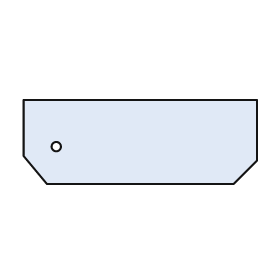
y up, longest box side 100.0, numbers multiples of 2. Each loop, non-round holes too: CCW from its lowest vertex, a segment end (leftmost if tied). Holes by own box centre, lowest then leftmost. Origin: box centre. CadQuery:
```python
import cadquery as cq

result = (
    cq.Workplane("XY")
    .moveTo(-40.0, -18.0)
    .lineTo(40.0, -18.0)
    .lineTo(50.0, -8.0)
    .lineTo(50.0, 18.0)
    .lineTo(-50.0, 18.0)
    .lineTo(-50.0, -6.0)
    .close()
    .moveTo(-36.0, -2.0)
    .circle(2.0)
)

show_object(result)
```